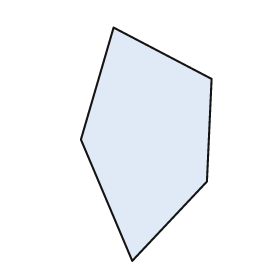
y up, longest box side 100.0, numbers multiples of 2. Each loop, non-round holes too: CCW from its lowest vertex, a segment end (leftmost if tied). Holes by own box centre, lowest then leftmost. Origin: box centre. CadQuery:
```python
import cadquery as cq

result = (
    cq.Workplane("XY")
    .moveTo(-6.0, -50.0)
    .lineTo(26.0, -16.0)
    .lineTo(28.0, 28.0)
    .lineTo(-14.0, 50.0)
    .lineTo(-28.0, 2.0)
    .close()
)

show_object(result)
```